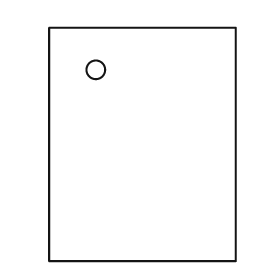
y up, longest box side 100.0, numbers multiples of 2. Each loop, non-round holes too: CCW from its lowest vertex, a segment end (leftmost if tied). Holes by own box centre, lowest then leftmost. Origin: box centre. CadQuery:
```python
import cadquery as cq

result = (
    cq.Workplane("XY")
    .moveTo(-40.0, -50.0)
    .lineTo(40.0, -50.0)
    .lineTo(40.0, 50.0)
    .lineTo(-40.0, 50.0)
    .close()
    .moveTo(-20.0, 32.0)
    .circle(4.0)
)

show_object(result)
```